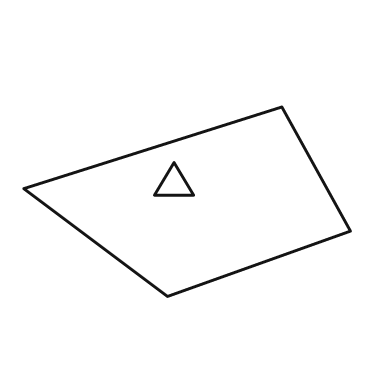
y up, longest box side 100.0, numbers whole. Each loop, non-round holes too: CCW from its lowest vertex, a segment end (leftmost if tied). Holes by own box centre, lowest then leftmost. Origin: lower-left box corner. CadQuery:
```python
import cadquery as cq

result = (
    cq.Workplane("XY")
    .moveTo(44.0, 0.0)
    .lineTo(100.0, 20.0)
    .lineTo(79.0, 58.0)
    .lineTo(0.0, 33.0)
    .close()
    .moveTo(40.0, 31.0)
    .lineTo(52.0, 31.0)
    .lineTo(46.0, 41.0)
    .close()
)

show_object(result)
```